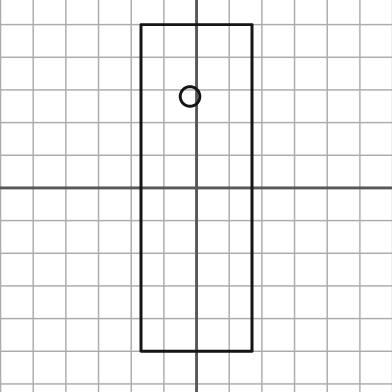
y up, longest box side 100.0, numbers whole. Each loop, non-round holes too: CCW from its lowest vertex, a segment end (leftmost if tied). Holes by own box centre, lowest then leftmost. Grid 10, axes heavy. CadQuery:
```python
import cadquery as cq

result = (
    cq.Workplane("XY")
    .moveTo(-17.0, -50.0)
    .lineTo(17.0, -50.0)
    .lineTo(17.0, 50.0)
    .lineTo(-17.0, 50.0)
    .close()
    .moveTo(-2.0, 28.0)
    .circle(3.0)
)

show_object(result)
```